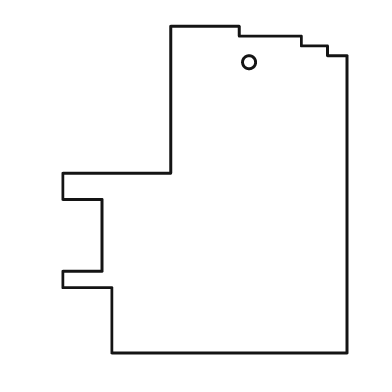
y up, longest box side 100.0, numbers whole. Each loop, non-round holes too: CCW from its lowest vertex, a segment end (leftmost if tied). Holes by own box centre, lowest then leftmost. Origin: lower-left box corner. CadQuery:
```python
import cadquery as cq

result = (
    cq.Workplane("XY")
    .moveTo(15.0, 0.0)
    .lineTo(87.0, 0.0)
    .lineTo(87.0, 91.0)
    .lineTo(81.0, 91.0)
    .lineTo(81.0, 94.0)
    .lineTo(73.0, 94.0)
    .lineTo(73.0, 97.0)
    .lineTo(54.0, 97.0)
    .lineTo(54.0, 100.0)
    .lineTo(33.0, 100.0)
    .lineTo(33.0, 55.0)
    .lineTo(0.0, 55.0)
    .lineTo(0.0, 47.0)
    .lineTo(12.0, 47.0)
    .lineTo(12.0, 25.0)
    .lineTo(0.0, 25.0)
    .lineTo(0.0, 20.0)
    .lineTo(15.0, 20.0)
    .close()
    .moveTo(57.0, 89.0)
    .circle(2.0)
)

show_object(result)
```